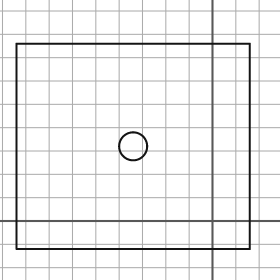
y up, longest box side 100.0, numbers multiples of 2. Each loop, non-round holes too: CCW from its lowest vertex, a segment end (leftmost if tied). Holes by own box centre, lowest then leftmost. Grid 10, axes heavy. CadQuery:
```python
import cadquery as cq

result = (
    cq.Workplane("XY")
    .moveTo(-84.0, -12.0)
    .lineTo(16.0, -12.0)
    .lineTo(16.0, 76.0)
    .lineTo(-84.0, 76.0)
    .close()
    .moveTo(-34.0, 32.0)
    .circle(6.0)
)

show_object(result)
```